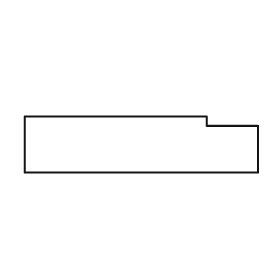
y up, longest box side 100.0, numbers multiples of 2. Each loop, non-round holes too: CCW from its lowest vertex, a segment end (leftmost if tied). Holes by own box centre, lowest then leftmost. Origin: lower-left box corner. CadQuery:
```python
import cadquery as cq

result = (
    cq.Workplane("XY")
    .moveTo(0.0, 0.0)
    .lineTo(100.0, 0.0)
    .lineTo(100.0, 20.0)
    .lineTo(78.0, 20.0)
    .lineTo(78.0, 24.0)
    .lineTo(0.0, 24.0)
    .close()
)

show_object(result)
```